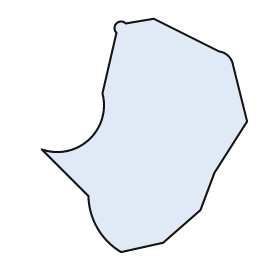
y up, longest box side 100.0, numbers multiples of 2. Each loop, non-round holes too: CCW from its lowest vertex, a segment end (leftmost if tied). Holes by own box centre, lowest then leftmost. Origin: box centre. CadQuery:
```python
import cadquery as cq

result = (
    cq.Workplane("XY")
    .moveTo(-10.0, -50.0)
    .lineTo(8.0, -46.0)
    .lineTo(24.0, -32.0)
    .lineTo(30.0, -16.0)
    .lineTo(44.0, 6.0)
    .lineTo(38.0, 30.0)
    .threePointArc((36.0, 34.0), (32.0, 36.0))
    .lineTo(4.0, 50.0)
    .lineTo(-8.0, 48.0)
    .threePointArc((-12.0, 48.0), (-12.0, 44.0))
    .lineTo(-18.0, 18.0)
    .threePointArc((-24.0, -2.0), (-44.0, -6.0))
    .lineTo(-24.0, -26.0)
    .threePointArc((-20.0, -40.0), (-10.0, -50.0))
    .close()
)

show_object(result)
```